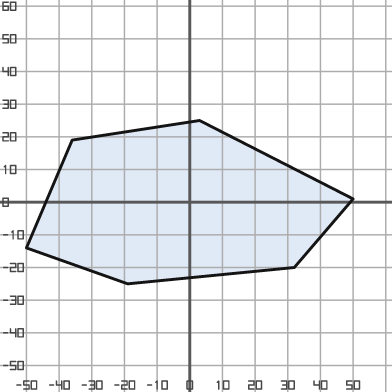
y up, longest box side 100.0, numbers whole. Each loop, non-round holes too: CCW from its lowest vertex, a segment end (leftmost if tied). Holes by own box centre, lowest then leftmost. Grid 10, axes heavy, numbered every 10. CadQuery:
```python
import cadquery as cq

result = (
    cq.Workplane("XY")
    .moveTo(-19.0, -25.0)
    .lineTo(32.0, -20.0)
    .lineTo(50.0, 1.0)
    .lineTo(3.0, 25.0)
    .lineTo(-36.0, 19.0)
    .lineTo(-50.0, -14.0)
    .close()
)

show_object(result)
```